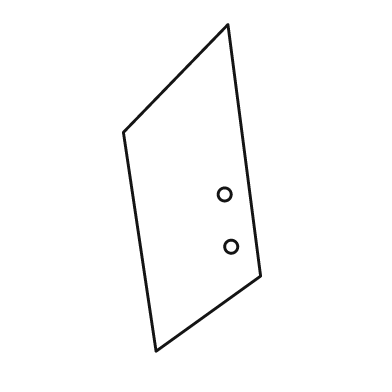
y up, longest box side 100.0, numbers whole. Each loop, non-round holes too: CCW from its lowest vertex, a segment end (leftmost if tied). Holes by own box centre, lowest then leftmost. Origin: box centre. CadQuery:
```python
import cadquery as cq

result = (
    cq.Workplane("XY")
    .moveTo(-11.0, -50.0)
    .lineTo(21.0, -27.0)
    .lineTo(11.0, 50.0)
    .lineTo(-21.0, 17.0)
    .close()
    .moveTo(12.0, -18.0)
    .circle(2.0)
    .moveTo(10.0, -2.0)
    .circle(2.0)
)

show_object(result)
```